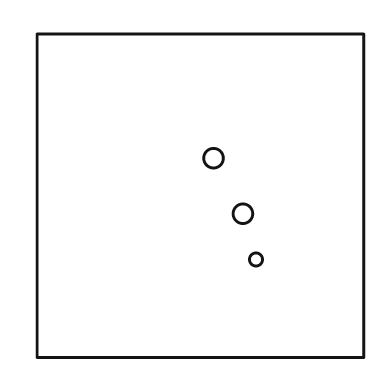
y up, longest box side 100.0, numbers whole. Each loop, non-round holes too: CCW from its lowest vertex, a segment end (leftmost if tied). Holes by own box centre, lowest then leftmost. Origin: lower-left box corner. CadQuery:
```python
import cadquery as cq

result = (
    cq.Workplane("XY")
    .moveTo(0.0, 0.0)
    .lineTo(100.0, 0.0)
    .lineTo(100.0, 99.0)
    .lineTo(0.0, 99.0)
    .close()
    .moveTo(67.0, 30.0)
    .circle(2.0)
    .moveTo(63.0, 44.0)
    .circle(3.0)
    .moveTo(54.0, 61.0)
    .circle(3.0)
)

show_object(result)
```